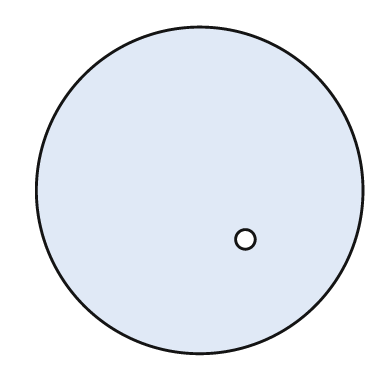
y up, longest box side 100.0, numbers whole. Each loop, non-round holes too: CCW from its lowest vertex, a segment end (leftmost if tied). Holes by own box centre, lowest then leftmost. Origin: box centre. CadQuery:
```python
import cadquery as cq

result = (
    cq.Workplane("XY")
    .moveTo(0.0, 0.0)
    .circle(50.0)
    .moveTo(14.0, -15.0)
    .circle(3.0)
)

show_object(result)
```